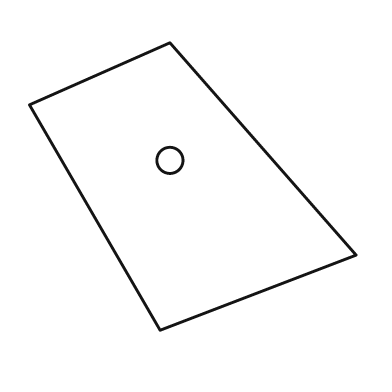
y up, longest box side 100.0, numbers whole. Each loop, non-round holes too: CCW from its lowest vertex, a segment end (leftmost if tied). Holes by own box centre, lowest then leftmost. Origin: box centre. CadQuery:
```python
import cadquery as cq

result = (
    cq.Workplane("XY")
    .moveTo(-10.0, -44.0)
    .lineTo(50.0, -21.0)
    .lineTo(-7.0, 44.0)
    .lineTo(-50.0, 25.0)
    .close()
    .moveTo(-7.0, 8.0)
    .circle(4.0)
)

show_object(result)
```